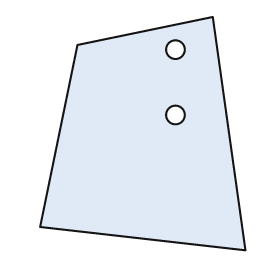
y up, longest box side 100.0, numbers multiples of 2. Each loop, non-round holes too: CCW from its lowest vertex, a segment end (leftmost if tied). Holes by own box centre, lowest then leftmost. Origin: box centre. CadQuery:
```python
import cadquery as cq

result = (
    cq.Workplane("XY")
    .moveTo(44.0, -50.0)
    .lineTo(30.0, 50.0)
    .lineTo(-28.0, 38.0)
    .lineTo(-44.0, -40.0)
    .close()
    .moveTo(14.0, 8.0)
    .circle(4.0)
    .moveTo(14.0, 36.0)
    .circle(4.0)
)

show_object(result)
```